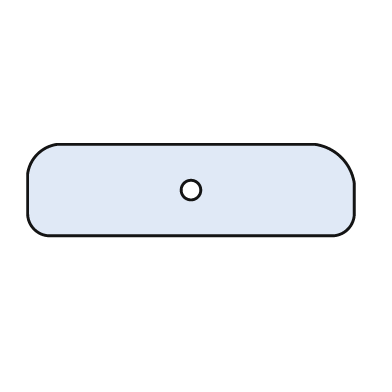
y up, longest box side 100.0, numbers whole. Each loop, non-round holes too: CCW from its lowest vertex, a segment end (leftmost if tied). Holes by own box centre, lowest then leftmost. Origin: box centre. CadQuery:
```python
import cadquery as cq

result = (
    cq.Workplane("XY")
    .moveTo(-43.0, -14.0)
    .lineTo(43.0, -14.0)
    .threePointArc((48.0, -12.0), (50.0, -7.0))
    .lineTo(50.0, 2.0)
    .threePointArc((46.0, 10.0), (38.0, 14.0))
    .lineTo(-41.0, 14.0)
    .threePointArc((-47.0, 11.0), (-50.0, 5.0))
    .lineTo(-50.0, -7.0)
    .threePointArc((-48.0, -12.0), (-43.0, -14.0))
    .close()
    .moveTo(0.0, 0.0)
    .circle(3.0)
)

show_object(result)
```